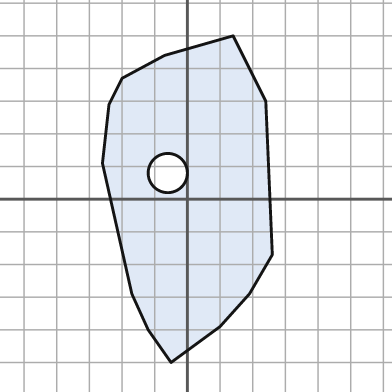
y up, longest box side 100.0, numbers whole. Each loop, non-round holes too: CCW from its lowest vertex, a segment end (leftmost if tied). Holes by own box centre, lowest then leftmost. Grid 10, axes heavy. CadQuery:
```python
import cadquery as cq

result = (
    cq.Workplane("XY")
    .moveTo(-5.0, -50.0)
    .lineTo(10.0, -39.0)
    .lineTo(19.0, -29.0)
    .lineTo(26.0, -17.0)
    .lineTo(24.0, 30.0)
    .lineTo(14.0, 50.0)
    .lineTo(-7.0, 44.0)
    .lineTo(-20.0, 37.0)
    .lineTo(-24.0, 29.0)
    .lineTo(-26.0, 11.0)
    .lineTo(-17.0, -29.0)
    .lineTo(-12.0, -40.0)
    .close()
    .moveTo(-6.0, 8.0)
    .circle(6.0)
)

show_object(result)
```